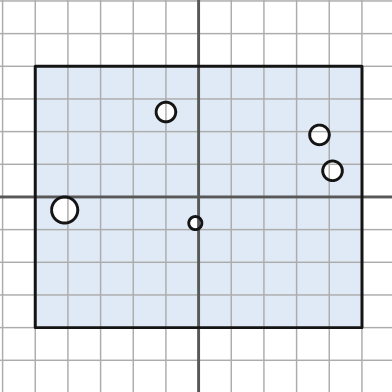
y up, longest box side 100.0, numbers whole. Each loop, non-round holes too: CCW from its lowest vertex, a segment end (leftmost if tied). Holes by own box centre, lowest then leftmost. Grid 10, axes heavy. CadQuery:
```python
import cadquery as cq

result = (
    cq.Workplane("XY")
    .moveTo(-50.0, -40.0)
    .lineTo(50.0, -40.0)
    .lineTo(50.0, 40.0)
    .lineTo(-50.0, 40.0)
    .close()
    .moveTo(-1.0, -8.0)
    .circle(2.0)
    .moveTo(-41.0, -4.0)
    .circle(4.0)
    .moveTo(41.0, 8.0)
    .circle(3.0)
    .moveTo(37.0, 19.0)
    .circle(3.0)
    .moveTo(-10.0, 26.0)
    .circle(3.0)
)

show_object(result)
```